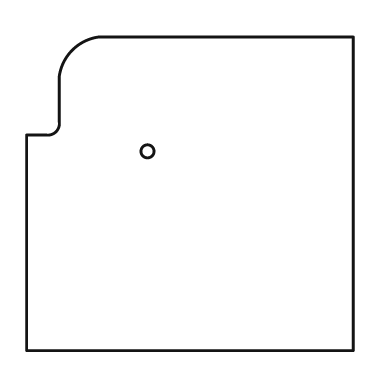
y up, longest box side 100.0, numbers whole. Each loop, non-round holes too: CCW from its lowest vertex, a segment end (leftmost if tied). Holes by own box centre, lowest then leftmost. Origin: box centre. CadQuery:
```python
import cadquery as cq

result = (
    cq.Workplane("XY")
    .moveTo(-50.0, -48.0)
    .lineTo(50.0, -48.0)
    .lineTo(50.0, 48.0)
    .lineTo(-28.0, 48.0)
    .threePointArc((-36.0, 44.0), (-40.0, 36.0))
    .lineTo(-40.0, 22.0)
    .threePointArc((-41.0, 19.0), (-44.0, 18.0))
    .lineTo(-50.0, 18.0)
    .close()
    .moveTo(-13.0, 13.0)
    .circle(2.0)
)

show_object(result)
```